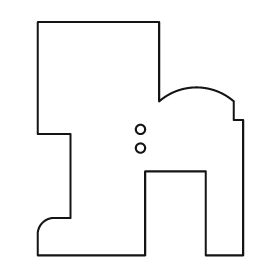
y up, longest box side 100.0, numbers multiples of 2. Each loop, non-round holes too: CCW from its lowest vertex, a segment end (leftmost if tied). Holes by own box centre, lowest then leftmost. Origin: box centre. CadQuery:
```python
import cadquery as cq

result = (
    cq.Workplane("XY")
    .moveTo(-44.0, -50.0)
    .lineTo(2.0, -50.0)
    .lineTo(2.0, -14.0)
    .lineTo(28.0, -14.0)
    .lineTo(28.0, -50.0)
    .lineTo(44.0, -50.0)
    .lineTo(44.0, 8.0)
    .lineTo(40.0, 8.0)
    .lineTo(40.0, 16.0)
    .threePointArc((24.0, 22.0), (8.0, 16.0))
    .lineTo(8.0, 50.0)
    .lineTo(-44.0, 50.0)
    .lineTo(-44.0, 2.0)
    .lineTo(-30.0, 2.0)
    .lineTo(-30.0, -34.0)
    .lineTo(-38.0, -34.0)
    .threePointArc((-42.0, -36.0), (-44.0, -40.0))
    .close()
    .moveTo(0.0, -4.0)
    .circle(2.0)
    .moveTo(0.0, 4.0)
    .circle(2.0)
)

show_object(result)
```